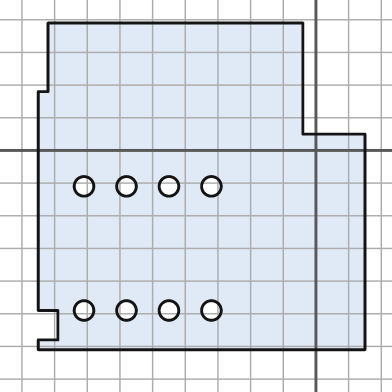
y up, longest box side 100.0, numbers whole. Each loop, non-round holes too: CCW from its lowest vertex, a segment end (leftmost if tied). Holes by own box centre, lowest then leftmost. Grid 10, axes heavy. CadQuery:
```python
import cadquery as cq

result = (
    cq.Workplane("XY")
    .moveTo(-85.0, -61.0)
    .lineTo(15.0, -61.0)
    .lineTo(15.0, 5.0)
    .lineTo(-4.0, 5.0)
    .lineTo(-4.0, 39.0)
    .lineTo(-82.0, 39.0)
    .lineTo(-82.0, 18.0)
    .lineTo(-85.0, 18.0)
    .lineTo(-85.0, -49.0)
    .lineTo(-79.0, -49.0)
    .lineTo(-79.0, -58.0)
    .lineTo(-85.0, -58.0)
    .close()
    .moveTo(-71.0, -49.0)
    .circle(3.0)
    .moveTo(-58.0, -49.0)
    .circle(3.0)
    .moveTo(-45.0, -49.0)
    .circle(3.0)
    .moveTo(-32.0, -49.0)
    .circle(3.0)
    .moveTo(-71.0, -11.0)
    .circle(3.0)
    .moveTo(-58.0, -11.0)
    .circle(3.0)
    .moveTo(-45.0, -11.0)
    .circle(3.0)
    .moveTo(-32.0, -11.0)
    .circle(3.0)
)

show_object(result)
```